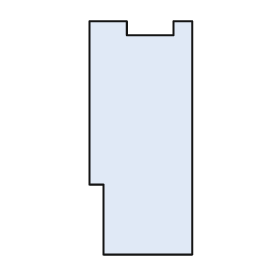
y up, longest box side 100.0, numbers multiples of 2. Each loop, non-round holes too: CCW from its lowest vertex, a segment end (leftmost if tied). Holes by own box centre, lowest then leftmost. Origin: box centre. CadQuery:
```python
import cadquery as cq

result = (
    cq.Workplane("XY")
    .moveTo(-16.0, -50.0)
    .lineTo(22.0, -50.0)
    .lineTo(22.0, 50.0)
    .lineTo(14.0, 50.0)
    .lineTo(14.0, 44.0)
    .lineTo(-6.0, 44.0)
    .lineTo(-6.0, 50.0)
    .lineTo(-22.0, 50.0)
    .lineTo(-22.0, -20.0)
    .lineTo(-16.0, -20.0)
    .close()
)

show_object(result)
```